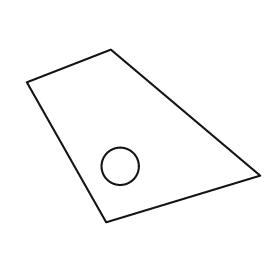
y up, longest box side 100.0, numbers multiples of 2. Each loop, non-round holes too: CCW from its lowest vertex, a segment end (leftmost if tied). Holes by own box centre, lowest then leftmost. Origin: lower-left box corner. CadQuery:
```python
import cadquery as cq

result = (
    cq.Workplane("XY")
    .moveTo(34.0, 0.0)
    .lineTo(100.0, 20.0)
    .lineTo(36.0, 74.0)
    .lineTo(0.0, 60.0)
    .close()
    .moveTo(40.0, 24.0)
    .circle(8.0)
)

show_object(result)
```